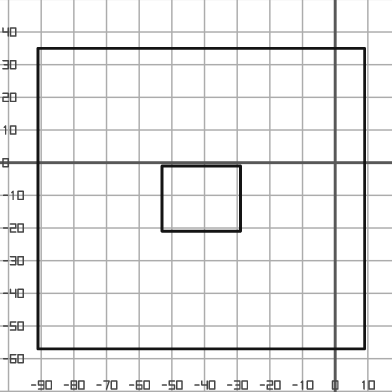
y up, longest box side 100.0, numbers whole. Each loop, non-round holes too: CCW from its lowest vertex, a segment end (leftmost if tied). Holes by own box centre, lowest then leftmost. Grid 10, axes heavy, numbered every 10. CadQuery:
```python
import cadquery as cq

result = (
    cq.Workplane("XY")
    .moveTo(-91.0, -57.0)
    .lineTo(9.0, -57.0)
    .lineTo(9.0, 35.0)
    .lineTo(-91.0, 35.0)
    .close()
    .moveTo(-53.0, -21.0)
    .lineTo(-29.0, -21.0)
    .lineTo(-29.0, -1.0)
    .lineTo(-53.0, -1.0)
    .close()
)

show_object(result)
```